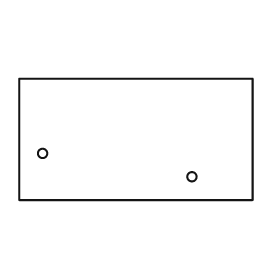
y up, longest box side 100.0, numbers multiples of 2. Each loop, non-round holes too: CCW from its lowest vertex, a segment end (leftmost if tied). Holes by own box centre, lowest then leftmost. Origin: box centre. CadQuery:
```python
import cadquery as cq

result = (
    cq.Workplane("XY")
    .moveTo(-50.0, -26.0)
    .lineTo(50.0, -26.0)
    .lineTo(50.0, 26.0)
    .lineTo(-50.0, 26.0)
    .close()
    .moveTo(24.0, -16.0)
    .circle(2.0)
    .moveTo(-40.0, -6.0)
    .circle(2.0)
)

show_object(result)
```